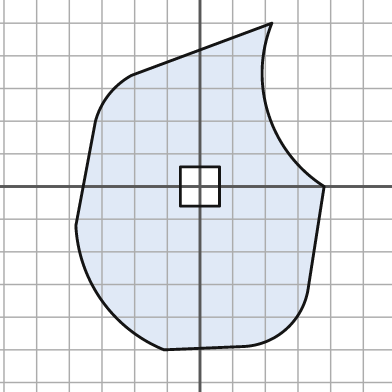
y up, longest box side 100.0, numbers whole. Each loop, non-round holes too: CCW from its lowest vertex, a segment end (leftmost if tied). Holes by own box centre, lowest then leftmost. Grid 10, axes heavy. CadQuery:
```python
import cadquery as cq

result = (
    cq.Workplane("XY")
    .moveTo(-11.0, -50.0)
    .lineTo(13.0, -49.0)
    .threePointArc((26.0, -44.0), (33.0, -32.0))
    .lineTo(38.0, 0.0)
    .threePointArc((21.0, 22.0), (22.0, 50.0))
    .lineTo(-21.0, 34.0)
    .threePointArc((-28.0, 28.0), (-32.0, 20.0))
    .lineTo(-38.0, -12.0)
    .threePointArc((-30.0, -35.0), (-11.0, -50.0))
    .close()
    .moveTo(-6.0, -6.0)
    .lineTo(6.0, -6.0)
    .lineTo(6.0, 6.0)
    .lineTo(-6.0, 6.0)
    .close()
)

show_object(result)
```